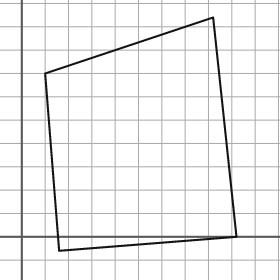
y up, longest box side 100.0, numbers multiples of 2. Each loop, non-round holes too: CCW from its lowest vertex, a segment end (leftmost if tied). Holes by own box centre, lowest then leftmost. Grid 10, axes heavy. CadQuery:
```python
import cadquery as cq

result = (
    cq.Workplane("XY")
    .moveTo(16.0, -6.0)
    .lineTo(92.0, 0.0)
    .lineTo(82.0, 94.0)
    .lineTo(10.0, 70.0)
    .close()
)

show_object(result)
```